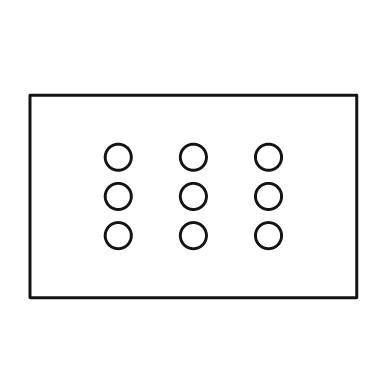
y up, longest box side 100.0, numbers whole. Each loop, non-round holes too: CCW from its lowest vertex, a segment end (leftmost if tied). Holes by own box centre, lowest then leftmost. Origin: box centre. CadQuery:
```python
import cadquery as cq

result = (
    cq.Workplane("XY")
    .moveTo(-50.0, -31.0)
    .lineTo(50.0, -31.0)
    .lineTo(50.0, 31.0)
    .lineTo(-50.0, 31.0)
    .close()
    .moveTo(-23.0, -12.0)
    .circle(4.0)
    .moveTo(0.0, -12.0)
    .circle(4.0)
    .moveTo(23.0, -12.0)
    .circle(4.0)
    .moveTo(-23.0, 0.0)
    .circle(4.0)
    .moveTo(0.0, 0.0)
    .circle(4.0)
    .moveTo(23.0, 0.0)
    .circle(4.0)
    .moveTo(-23.0, 12.0)
    .circle(4.0)
    .moveTo(0.0, 12.0)
    .circle(4.0)
    .moveTo(23.0, 12.0)
    .circle(4.0)
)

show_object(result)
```